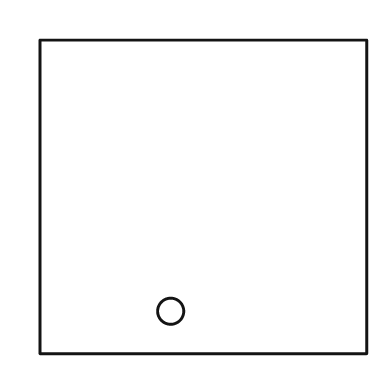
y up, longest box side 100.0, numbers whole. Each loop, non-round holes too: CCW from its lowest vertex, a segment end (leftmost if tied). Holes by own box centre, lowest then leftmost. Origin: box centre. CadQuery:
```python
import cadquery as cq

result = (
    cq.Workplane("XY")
    .moveTo(-50.0, -48.0)
    .lineTo(50.0, -48.0)
    .lineTo(50.0, 48.0)
    .lineTo(-50.0, 48.0)
    .close()
    .moveTo(-10.0, -35.0)
    .circle(4.0)
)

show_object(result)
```